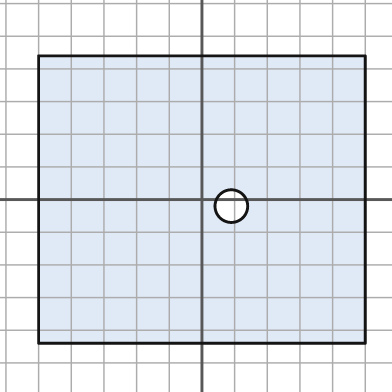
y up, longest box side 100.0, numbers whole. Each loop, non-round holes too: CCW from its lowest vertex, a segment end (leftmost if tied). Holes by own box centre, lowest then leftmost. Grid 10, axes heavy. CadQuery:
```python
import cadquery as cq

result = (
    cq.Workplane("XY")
    .moveTo(-50.0, -44.0)
    .lineTo(50.0, -44.0)
    .lineTo(50.0, 44.0)
    .lineTo(-50.0, 44.0)
    .close()
    .moveTo(9.0, -2.0)
    .circle(5.0)
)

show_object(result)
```